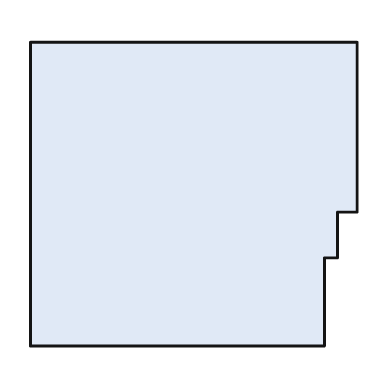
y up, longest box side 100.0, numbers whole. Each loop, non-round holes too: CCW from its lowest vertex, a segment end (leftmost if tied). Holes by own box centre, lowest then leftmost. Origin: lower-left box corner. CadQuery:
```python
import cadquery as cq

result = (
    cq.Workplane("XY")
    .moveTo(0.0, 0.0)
    .lineTo(90.0, 0.0)
    .lineTo(90.0, 27.0)
    .lineTo(94.0, 27.0)
    .lineTo(94.0, 41.0)
    .lineTo(100.0, 41.0)
    .lineTo(100.0, 93.0)
    .lineTo(0.0, 93.0)
    .close()
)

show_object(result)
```